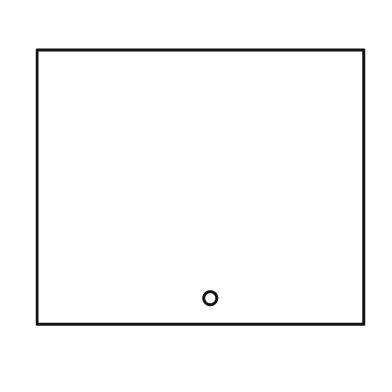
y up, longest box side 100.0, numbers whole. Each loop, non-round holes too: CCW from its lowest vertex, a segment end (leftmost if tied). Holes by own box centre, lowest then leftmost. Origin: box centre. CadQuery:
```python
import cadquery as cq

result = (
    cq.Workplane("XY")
    .moveTo(-50.0, -42.0)
    .lineTo(50.0, -42.0)
    .lineTo(50.0, 42.0)
    .lineTo(-50.0, 42.0)
    .close()
    .moveTo(3.0, -34.0)
    .circle(2.0)
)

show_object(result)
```